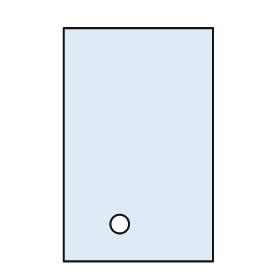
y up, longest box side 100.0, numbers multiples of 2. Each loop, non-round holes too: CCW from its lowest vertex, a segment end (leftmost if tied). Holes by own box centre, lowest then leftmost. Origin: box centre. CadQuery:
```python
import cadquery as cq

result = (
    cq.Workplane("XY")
    .moveTo(-32.0, -50.0)
    .lineTo(32.0, -50.0)
    .lineTo(32.0, 50.0)
    .lineTo(-32.0, 50.0)
    .close()
    .moveTo(-8.0, -34.0)
    .circle(4.0)
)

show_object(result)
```